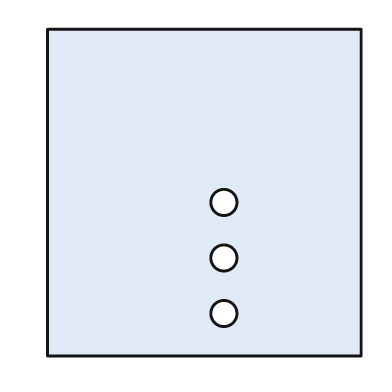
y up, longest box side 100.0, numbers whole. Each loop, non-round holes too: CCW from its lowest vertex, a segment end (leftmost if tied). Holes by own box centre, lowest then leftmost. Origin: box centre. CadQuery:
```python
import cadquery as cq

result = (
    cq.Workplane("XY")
    .moveTo(-48.0, -50.0)
    .lineTo(48.0, -50.0)
    .lineTo(48.0, 50.0)
    .lineTo(-48.0, 50.0)
    .close()
    .moveTo(6.0, -37.0)
    .circle(4.0)
    .moveTo(6.0, -20.0)
    .circle(4.0)
    .moveTo(6.0, -3.0)
    .circle(4.0)
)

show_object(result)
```